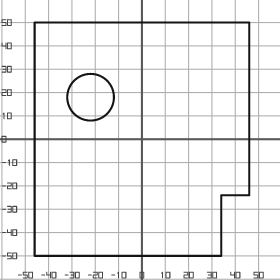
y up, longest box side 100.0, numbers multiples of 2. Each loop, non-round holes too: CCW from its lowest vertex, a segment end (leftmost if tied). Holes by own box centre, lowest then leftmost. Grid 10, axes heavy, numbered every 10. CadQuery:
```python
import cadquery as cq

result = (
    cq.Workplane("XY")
    .moveTo(-46.0, -50.0)
    .lineTo(34.0, -50.0)
    .lineTo(34.0, -24.0)
    .lineTo(46.0, -24.0)
    .lineTo(46.0, 50.0)
    .lineTo(-46.0, 50.0)
    .close()
    .moveTo(-22.0, 18.0)
    .circle(10.0)
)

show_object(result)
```